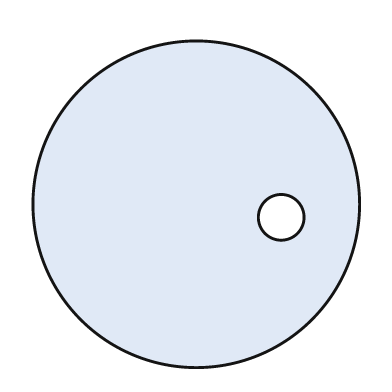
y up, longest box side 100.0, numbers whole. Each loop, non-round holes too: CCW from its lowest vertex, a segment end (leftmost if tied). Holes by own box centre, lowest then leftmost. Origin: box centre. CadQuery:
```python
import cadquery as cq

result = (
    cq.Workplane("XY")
    .moveTo(0.0, 0.0)
    .circle(50.0)
    .moveTo(26.0, -4.0)
    .circle(7.0)
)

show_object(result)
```